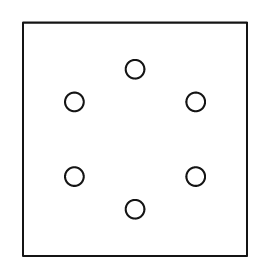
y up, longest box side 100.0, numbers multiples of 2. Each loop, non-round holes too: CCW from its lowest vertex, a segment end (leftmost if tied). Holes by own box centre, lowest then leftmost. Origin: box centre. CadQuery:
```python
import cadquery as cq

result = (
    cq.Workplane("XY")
    .moveTo(-48.0, -50.0)
    .lineTo(48.0, -50.0)
    .lineTo(48.0, 50.0)
    .lineTo(-48.0, 50.0)
    .close()
    .moveTo(0.0, -30.0)
    .circle(4.0)
    .moveTo(-26.0, -16.0)
    .circle(4.0)
    .moveTo(26.0, -16.0)
    .circle(4.0)
    .moveTo(-26.0, 16.0)
    .circle(4.0)
    .moveTo(26.0, 16.0)
    .circle(4.0)
    .moveTo(0.0, 30.0)
    .circle(4.0)
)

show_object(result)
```